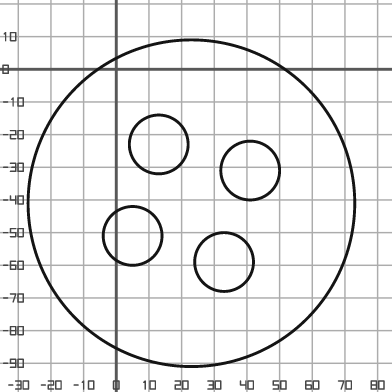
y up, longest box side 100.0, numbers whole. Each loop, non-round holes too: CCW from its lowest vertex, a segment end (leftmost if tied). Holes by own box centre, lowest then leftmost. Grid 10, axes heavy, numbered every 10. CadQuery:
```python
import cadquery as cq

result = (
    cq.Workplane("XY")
    .moveTo(23.0, -41.0)
    .circle(50.0)
    .moveTo(33.0, -59.0)
    .circle(9.0)
    .moveTo(5.0, -51.0)
    .circle(9.0)
    .moveTo(41.0, -31.0)
    .circle(9.0)
    .moveTo(13.0, -23.0)
    .circle(9.0)
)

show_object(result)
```